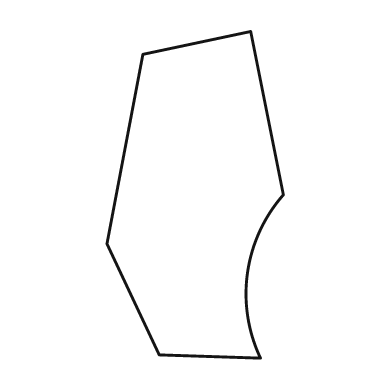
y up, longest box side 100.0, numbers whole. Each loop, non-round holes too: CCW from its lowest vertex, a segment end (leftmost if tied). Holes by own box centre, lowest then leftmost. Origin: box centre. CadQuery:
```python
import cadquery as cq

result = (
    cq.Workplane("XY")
    .moveTo(20.0, -50.0)
    .threePointArc((16.0, -24.0), (27.0, 0.0))
    .lineTo(17.0, 50.0)
    .lineTo(-16.0, 43.0)
    .lineTo(-27.0, -15.0)
    .lineTo(-11.0, -49.0)
    .close()
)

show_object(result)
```